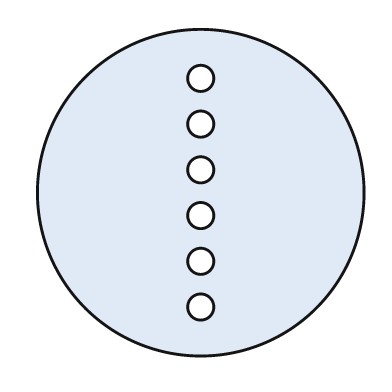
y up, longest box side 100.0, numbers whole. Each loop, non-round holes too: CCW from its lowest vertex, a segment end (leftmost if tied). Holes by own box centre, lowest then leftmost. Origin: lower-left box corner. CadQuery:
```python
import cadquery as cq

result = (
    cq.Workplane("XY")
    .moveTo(50.0, 50.0)
    .circle(50.0)
    .moveTo(50.0, 15.0)
    .circle(4.0)
    .moveTo(50.0, 29.0)
    .circle(4.0)
    .moveTo(50.0, 43.0)
    .circle(4.0)
    .moveTo(50.0, 57.0)
    .circle(4.0)
    .moveTo(50.0, 71.0)
    .circle(4.0)
    .moveTo(50.0, 85.0)
    .circle(4.0)
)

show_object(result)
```